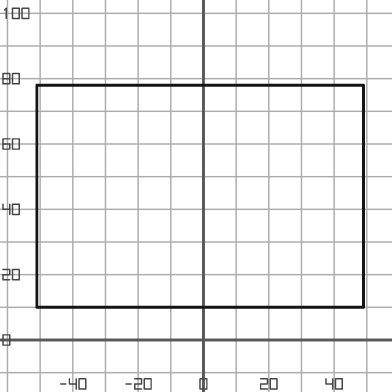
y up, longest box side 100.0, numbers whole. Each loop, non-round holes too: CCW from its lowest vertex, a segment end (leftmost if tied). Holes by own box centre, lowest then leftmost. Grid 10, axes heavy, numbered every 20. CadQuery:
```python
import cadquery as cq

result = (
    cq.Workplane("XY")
    .moveTo(-51.0, 10.0)
    .lineTo(49.0, 10.0)
    .lineTo(49.0, 78.0)
    .lineTo(-51.0, 78.0)
    .close()
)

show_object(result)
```